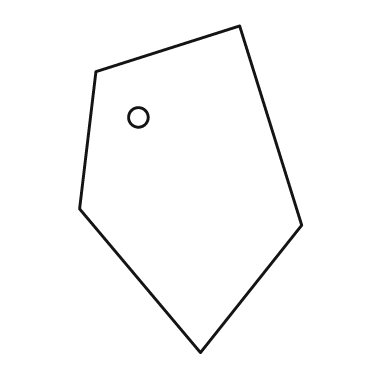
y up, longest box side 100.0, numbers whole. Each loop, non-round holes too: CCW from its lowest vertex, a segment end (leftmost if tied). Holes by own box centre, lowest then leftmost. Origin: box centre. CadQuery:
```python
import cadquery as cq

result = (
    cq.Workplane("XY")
    .moveTo(3.0, -50.0)
    .lineTo(34.0, -11.0)
    .lineTo(15.0, 50.0)
    .lineTo(-29.0, 36.0)
    .lineTo(-34.0, -6.0)
    .close()
    .moveTo(-16.0, 22.0)
    .circle(3.0)
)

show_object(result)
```